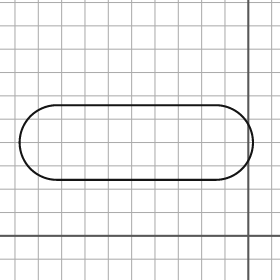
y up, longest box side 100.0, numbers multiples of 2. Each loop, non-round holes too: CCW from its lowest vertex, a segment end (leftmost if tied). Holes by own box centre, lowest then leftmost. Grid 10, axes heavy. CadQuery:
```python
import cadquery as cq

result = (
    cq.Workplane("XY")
    .moveTo(-82.0, 24.0)
    .lineTo(-14.0, 24.0)
    .threePointArc((2.0, 40.0), (-14.0, 56.0))
    .lineTo(-82.0, 56.0)
    .threePointArc((-98.0, 40.0), (-82.0, 24.0))
    .close()
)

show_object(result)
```